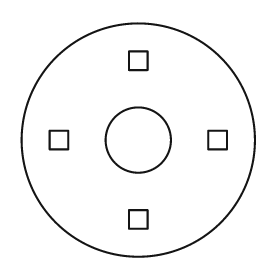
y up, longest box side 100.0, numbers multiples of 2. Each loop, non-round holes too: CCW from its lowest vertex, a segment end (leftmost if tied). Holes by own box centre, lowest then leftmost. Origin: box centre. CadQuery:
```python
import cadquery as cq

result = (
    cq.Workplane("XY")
    .moveTo(0.0, 0.0)
    .circle(50.0)
    .moveTo(-4.0, -38.0)
    .lineTo(4.0, -38.0)
    .lineTo(4.0, -30.0)
    .lineTo(-4.0, -30.0)
    .close()
    .moveTo(-38.0, -4.0)
    .lineTo(-30.0, -4.0)
    .lineTo(-30.0, 4.0)
    .lineTo(-38.0, 4.0)
    .close()
    .moveTo(0.0, 0.0)
    .circle(14.0)
    .moveTo(30.0, -4.0)
    .lineTo(38.0, -4.0)
    .lineTo(38.0, 4.0)
    .lineTo(30.0, 4.0)
    .close()
    .moveTo(-4.0, 30.0)
    .lineTo(4.0, 30.0)
    .lineTo(4.0, 38.0)
    .lineTo(-4.0, 38.0)
    .close()
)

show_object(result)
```